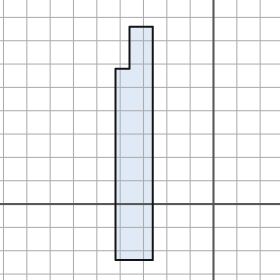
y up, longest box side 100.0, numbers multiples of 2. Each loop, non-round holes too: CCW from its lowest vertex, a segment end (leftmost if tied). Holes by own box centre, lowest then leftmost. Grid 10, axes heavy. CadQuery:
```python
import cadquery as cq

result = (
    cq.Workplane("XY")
    .moveTo(-42.0, -24.0)
    .lineTo(-26.0, -24.0)
    .lineTo(-26.0, 76.0)
    .lineTo(-36.0, 76.0)
    .lineTo(-36.0, 58.0)
    .lineTo(-42.0, 58.0)
    .close()
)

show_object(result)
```